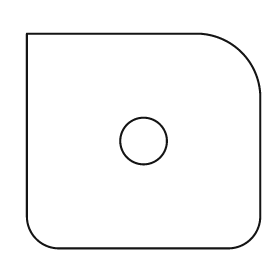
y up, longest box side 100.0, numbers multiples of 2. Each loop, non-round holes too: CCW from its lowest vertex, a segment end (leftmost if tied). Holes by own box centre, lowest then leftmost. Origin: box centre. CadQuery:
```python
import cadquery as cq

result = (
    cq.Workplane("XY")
    .moveTo(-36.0, -46.0)
    .lineTo(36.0, -46.0)
    .threePointArc((46.0, -42.0), (50.0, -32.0))
    .lineTo(50.0, 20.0)
    .threePointArc((42.0, 38.0), (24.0, 46.0))
    .lineTo(-50.0, 46.0)
    .lineTo(-50.0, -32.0)
    .threePointArc((-46.0, -42.0), (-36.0, -46.0))
    .close()
    .moveTo(0.0, 0.0)
    .circle(10.0)
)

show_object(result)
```